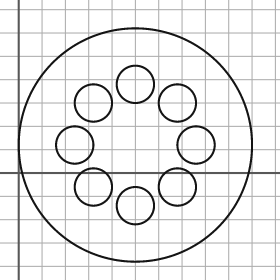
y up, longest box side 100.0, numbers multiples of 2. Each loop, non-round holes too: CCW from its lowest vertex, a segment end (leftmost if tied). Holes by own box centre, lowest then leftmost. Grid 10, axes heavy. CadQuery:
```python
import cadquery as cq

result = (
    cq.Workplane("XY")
    .moveTo(50.0, 12.0)
    .circle(50.0)
    .moveTo(50.0, -14.0)
    .circle(8.0)
    .moveTo(32.0, -6.0)
    .circle(8.0)
    .moveTo(68.0, -6.0)
    .circle(8.0)
    .moveTo(24.0, 12.0)
    .circle(8.0)
    .moveTo(76.0, 12.0)
    .circle(8.0)
    .moveTo(32.0, 30.0)
    .circle(8.0)
    .moveTo(68.0, 30.0)
    .circle(8.0)
    .moveTo(50.0, 38.0)
    .circle(8.0)
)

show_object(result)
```